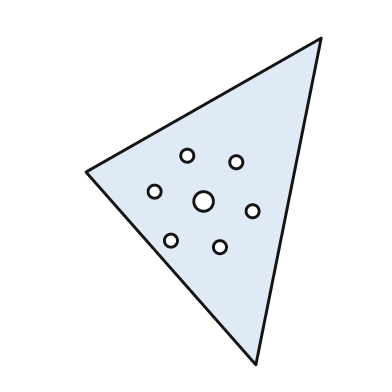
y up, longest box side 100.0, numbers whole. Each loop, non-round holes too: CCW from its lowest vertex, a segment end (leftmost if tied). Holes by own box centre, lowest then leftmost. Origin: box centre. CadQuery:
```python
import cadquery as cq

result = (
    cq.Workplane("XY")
    .moveTo(16.0, -50.0)
    .lineTo(36.0, 50.0)
    .lineTo(-36.0, 9.0)
    .close()
    .moveTo(5.0, -14.0)
    .circle(2.0)
    .moveTo(-10.0, -12.0)
    .circle(2.0)
    .moveTo(15.0, -3.0)
    .circle(2.0)
    .moveTo(0.0, 0.0)
    .circle(3.0)
    .moveTo(-15.0, 3.0)
    .circle(2.0)
    .moveTo(10.0, 12.0)
    .circle(2.0)
    .moveTo(-5.0, 14.0)
    .circle(2.0)
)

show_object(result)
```